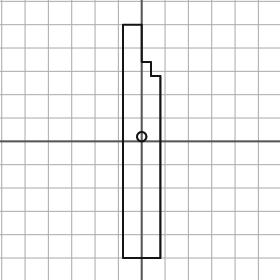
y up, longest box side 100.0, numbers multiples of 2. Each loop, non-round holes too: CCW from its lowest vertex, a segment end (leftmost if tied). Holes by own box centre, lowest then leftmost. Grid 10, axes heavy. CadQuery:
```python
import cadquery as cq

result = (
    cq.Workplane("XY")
    .moveTo(-8.0, -50.0)
    .lineTo(8.0, -50.0)
    .lineTo(8.0, 28.0)
    .lineTo(4.0, 28.0)
    .lineTo(4.0, 34.0)
    .lineTo(0.0, 34.0)
    .lineTo(0.0, 50.0)
    .lineTo(-8.0, 50.0)
    .close()
    .moveTo(0.0, 2.0)
    .circle(2.0)
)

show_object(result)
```